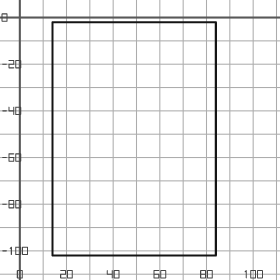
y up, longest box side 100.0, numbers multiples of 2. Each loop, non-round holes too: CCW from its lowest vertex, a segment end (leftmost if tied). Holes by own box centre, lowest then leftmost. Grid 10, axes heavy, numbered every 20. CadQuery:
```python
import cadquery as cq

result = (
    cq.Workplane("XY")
    .moveTo(14.0, -102.0)
    .lineTo(84.0, -102.0)
    .lineTo(84.0, -2.0)
    .lineTo(14.0, -2.0)
    .close()
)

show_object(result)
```